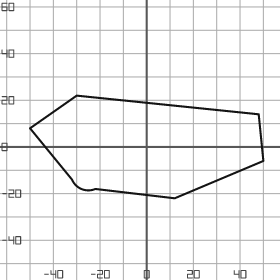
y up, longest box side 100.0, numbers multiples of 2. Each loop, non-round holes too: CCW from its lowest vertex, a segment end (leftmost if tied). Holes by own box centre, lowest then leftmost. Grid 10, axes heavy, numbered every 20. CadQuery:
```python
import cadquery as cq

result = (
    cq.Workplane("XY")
    .moveTo(12.0, -22.0)
    .lineTo(50.0, -6.0)
    .lineTo(48.0, 14.0)
    .lineTo(-30.0, 22.0)
    .lineTo(-50.0, 8.0)
    .lineTo(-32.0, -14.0)
    .threePointArc((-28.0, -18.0), (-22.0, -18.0))
    .close()
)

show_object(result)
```